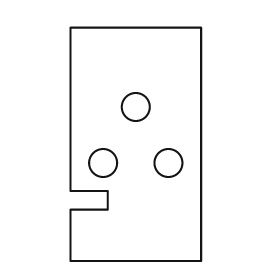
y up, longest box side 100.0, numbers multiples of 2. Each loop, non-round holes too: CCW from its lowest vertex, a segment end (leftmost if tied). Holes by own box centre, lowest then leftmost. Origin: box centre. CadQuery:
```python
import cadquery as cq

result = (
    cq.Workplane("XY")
    .moveTo(-28.0, -50.0)
    .lineTo(28.0, -50.0)
    .lineTo(28.0, 50.0)
    .lineTo(-28.0, 50.0)
    .lineTo(-28.0, -20.0)
    .lineTo(-12.0, -20.0)
    .lineTo(-12.0, -28.0)
    .lineTo(-28.0, -28.0)
    .close()
    .moveTo(-14.0, -8.0)
    .circle(6.0)
    .moveTo(14.0, -8.0)
    .circle(6.0)
    .moveTo(0.0, 16.0)
    .circle(6.0)
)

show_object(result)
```